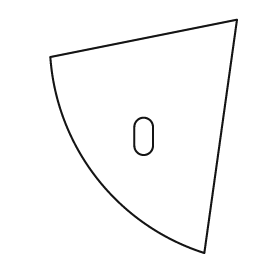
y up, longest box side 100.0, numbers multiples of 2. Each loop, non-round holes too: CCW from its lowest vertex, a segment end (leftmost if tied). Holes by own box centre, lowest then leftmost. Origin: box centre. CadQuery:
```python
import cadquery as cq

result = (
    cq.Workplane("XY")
    .moveTo(26.0, -50.0)
    .lineTo(40.0, 50.0)
    .lineTo(-40.0, 34.0)
    .threePointArc((-20.0, -18.0), (26.0, -50.0))
    .close()
    .moveTo(-4.0, -4.0)
    .threePointArc((0.0, -8.0), (4.0, -4.0))
    .lineTo(4.0, 4.0)
    .threePointArc((0.0, 8.0), (-4.0, 4.0))
    .close()
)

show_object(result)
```